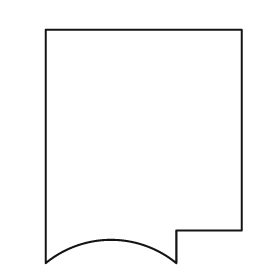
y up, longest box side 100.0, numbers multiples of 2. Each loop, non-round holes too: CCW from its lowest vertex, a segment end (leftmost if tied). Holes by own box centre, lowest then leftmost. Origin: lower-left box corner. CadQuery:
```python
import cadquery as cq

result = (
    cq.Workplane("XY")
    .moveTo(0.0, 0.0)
    .threePointArc((28.0, 10.0), (56.0, 0.0))
    .lineTo(56.0, 14.0)
    .lineTo(84.0, 14.0)
    .lineTo(84.0, 100.0)
    .lineTo(0.0, 100.0)
    .close()
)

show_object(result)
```